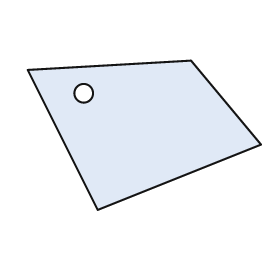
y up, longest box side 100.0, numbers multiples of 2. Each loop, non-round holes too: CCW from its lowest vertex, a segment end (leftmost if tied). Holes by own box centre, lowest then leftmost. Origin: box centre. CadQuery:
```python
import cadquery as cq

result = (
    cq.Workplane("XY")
    .moveTo(-20.0, -32.0)
    .lineTo(50.0, -4.0)
    .lineTo(20.0, 32.0)
    .lineTo(-50.0, 28.0)
    .close()
    .moveTo(-26.0, 18.0)
    .circle(4.0)
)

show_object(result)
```